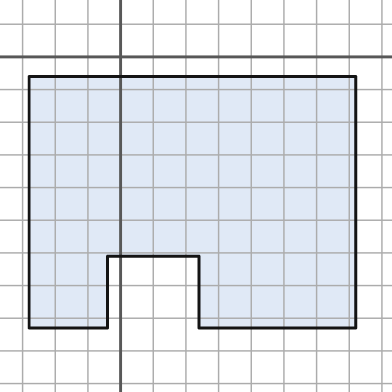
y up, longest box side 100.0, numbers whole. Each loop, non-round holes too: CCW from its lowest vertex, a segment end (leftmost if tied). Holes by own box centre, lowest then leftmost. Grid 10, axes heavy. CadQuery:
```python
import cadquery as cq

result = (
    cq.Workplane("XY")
    .moveTo(-28.0, -83.0)
    .lineTo(-4.0, -83.0)
    .lineTo(-4.0, -61.0)
    .lineTo(24.0, -61.0)
    .lineTo(24.0, -83.0)
    .lineTo(72.0, -83.0)
    .lineTo(72.0, -6.0)
    .lineTo(-28.0, -6.0)
    .close()
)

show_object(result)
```